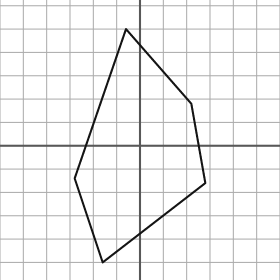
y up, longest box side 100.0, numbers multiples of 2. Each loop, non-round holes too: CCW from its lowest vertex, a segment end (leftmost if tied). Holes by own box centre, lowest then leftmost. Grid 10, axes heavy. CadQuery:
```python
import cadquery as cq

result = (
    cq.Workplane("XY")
    .moveTo(-16.0, -50.0)
    .lineTo(28.0, -16.0)
    .lineTo(22.0, 18.0)
    .lineTo(-6.0, 50.0)
    .lineTo(-28.0, -14.0)
    .close()
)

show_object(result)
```